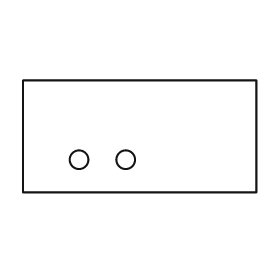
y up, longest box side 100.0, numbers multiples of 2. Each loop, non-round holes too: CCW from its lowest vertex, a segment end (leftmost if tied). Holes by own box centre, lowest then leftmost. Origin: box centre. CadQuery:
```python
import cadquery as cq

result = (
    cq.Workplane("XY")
    .moveTo(-50.0, -24.0)
    .lineTo(50.0, -24.0)
    .lineTo(50.0, 24.0)
    .lineTo(-50.0, 24.0)
    .close()
    .moveTo(-26.0, -10.0)
    .circle(4.0)
    .moveTo(-6.0, -10.0)
    .circle(4.0)
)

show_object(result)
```